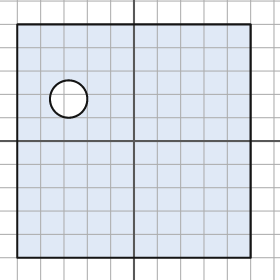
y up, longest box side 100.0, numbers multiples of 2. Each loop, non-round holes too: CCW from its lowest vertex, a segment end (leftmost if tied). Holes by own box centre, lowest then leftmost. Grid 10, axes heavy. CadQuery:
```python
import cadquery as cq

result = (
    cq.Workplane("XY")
    .moveTo(-50.0, -50.0)
    .lineTo(50.0, -50.0)
    .lineTo(50.0, 50.0)
    .lineTo(-50.0, 50.0)
    .close()
    .moveTo(-28.0, 18.0)
    .circle(8.0)
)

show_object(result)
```